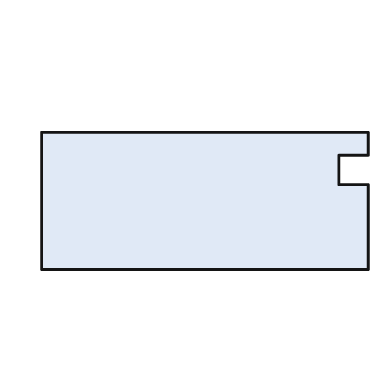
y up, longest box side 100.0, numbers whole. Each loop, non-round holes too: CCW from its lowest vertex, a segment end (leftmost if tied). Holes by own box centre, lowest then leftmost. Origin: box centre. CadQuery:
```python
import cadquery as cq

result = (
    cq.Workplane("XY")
    .moveTo(-50.0, -21.0)
    .lineTo(50.0, -21.0)
    .lineTo(50.0, 5.0)
    .lineTo(41.0, 5.0)
    .lineTo(41.0, 14.0)
    .lineTo(50.0, 14.0)
    .lineTo(50.0, 21.0)
    .lineTo(-50.0, 21.0)
    .close()
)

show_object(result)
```